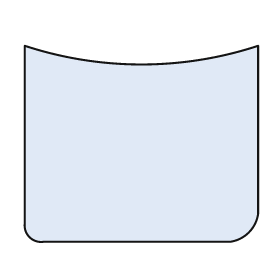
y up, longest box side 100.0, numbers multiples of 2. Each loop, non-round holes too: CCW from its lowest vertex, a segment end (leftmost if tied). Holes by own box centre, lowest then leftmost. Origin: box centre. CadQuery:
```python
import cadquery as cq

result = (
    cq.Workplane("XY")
    .moveTo(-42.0, -42.0)
    .lineTo(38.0, -42.0)
    .threePointArc((46.0, -38.0), (50.0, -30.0))
    .lineTo(50.0, 42.0)
    .threePointArc((0.0, 34.0), (-50.0, 42.0))
    .lineTo(-50.0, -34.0)
    .threePointArc((-48.0, -40.0), (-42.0, -42.0))
    .close()
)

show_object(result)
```